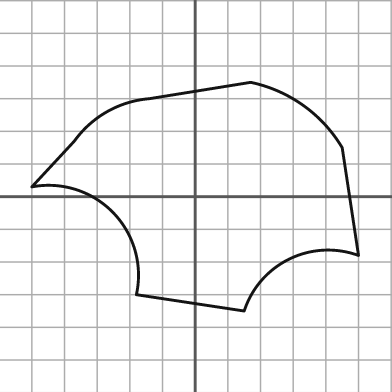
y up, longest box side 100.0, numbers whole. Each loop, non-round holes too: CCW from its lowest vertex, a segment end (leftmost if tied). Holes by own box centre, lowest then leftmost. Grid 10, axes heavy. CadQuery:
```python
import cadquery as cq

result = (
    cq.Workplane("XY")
    .moveTo(15.0, -35.0)
    .threePointArc((29.0, -19.0), (50.0, -18.0))
    .lineTo(45.0, 15.0)
    .threePointArc((33.0, 28.0), (17.0, 35.0))
    .lineTo(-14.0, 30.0)
    .threePointArc((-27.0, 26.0), (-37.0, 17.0))
    .lineTo(-50.0, 3.0)
    .threePointArc((-25.0, -5.0), (-18.0, -30.0))
    .close()
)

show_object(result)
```